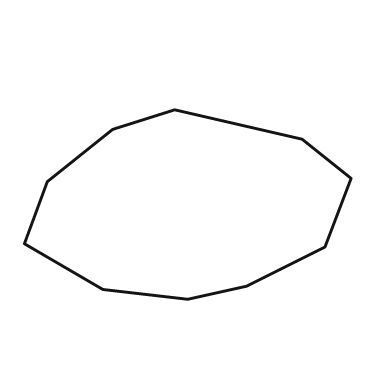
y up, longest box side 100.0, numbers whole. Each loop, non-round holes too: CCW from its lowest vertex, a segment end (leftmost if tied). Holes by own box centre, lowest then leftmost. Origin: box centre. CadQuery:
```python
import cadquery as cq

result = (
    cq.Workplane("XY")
    .moveTo(0.0, -29.0)
    .lineTo(18.0, -25.0)
    .lineTo(42.0, -13.0)
    .lineTo(50.0, 8.0)
    .lineTo(35.0, 20.0)
    .lineTo(-4.0, 29.0)
    .lineTo(-23.0, 23.0)
    .lineTo(-43.0, 7.0)
    .lineTo(-50.0, -12.0)
    .lineTo(-26.0, -26.0)
    .close()
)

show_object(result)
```